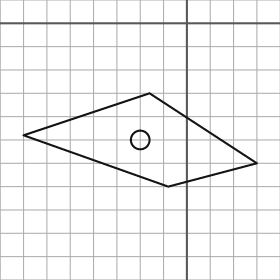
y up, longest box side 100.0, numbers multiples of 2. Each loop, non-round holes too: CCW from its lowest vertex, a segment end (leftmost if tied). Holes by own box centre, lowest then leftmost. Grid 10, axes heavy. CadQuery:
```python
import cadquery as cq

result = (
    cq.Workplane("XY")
    .moveTo(-8.0, -70.0)
    .lineTo(30.0, -60.0)
    .lineTo(-16.0, -30.0)
    .lineTo(-70.0, -48.0)
    .close()
    .moveTo(-20.0, -50.0)
    .circle(4.0)
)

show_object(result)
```